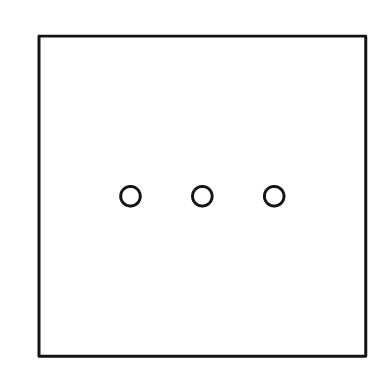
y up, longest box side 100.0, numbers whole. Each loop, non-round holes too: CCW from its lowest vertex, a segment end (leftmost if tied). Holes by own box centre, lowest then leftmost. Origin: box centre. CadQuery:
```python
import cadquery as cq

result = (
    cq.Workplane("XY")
    .moveTo(-50.0, -49.0)
    .lineTo(50.0, -49.0)
    .lineTo(50.0, 49.0)
    .lineTo(-50.0, 49.0)
    .close()
    .moveTo(-22.0, 0.0)
    .circle(3.0)
    .moveTo(0.0, 0.0)
    .circle(3.0)
    .moveTo(22.0, 0.0)
    .circle(3.0)
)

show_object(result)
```